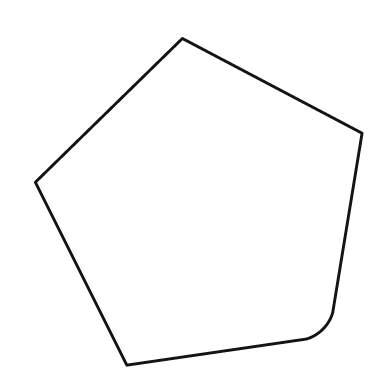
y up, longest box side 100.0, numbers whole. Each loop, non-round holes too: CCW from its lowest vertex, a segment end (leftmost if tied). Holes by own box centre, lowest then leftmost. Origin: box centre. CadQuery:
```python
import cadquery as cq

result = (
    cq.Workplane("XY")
    .moveTo(-22.0, -50.0)
    .lineTo(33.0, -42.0)
    .threePointArc((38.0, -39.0), (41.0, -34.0))
    .lineTo(50.0, 21.0)
    .lineTo(-5.0, 50.0)
    .lineTo(-50.0, 6.0)
    .close()
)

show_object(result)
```